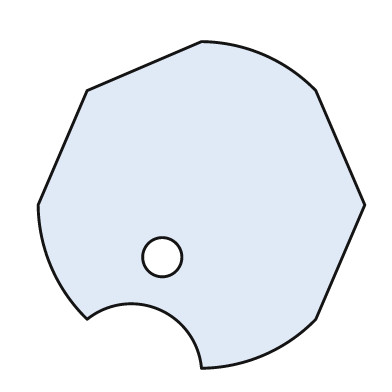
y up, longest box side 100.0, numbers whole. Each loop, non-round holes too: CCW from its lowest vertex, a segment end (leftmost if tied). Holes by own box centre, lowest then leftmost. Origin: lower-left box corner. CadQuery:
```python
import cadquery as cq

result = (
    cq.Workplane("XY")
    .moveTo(50.0, 0.0)
    .threePointArc((69.0, 4.0), (85.0, 15.0))
    .lineTo(100.0, 50.0)
    .lineTo(85.0, 85.0)
    .threePointArc((69.0, 96.0), (50.0, 100.0))
    .lineTo(15.0, 85.0)
    .lineTo(0.0, 50.0)
    .threePointArc((4.0, 31.0), (15.0, 15.0))
    .threePointArc((37.0, 18.0), (50.0, 0.0))
    .close()
    .moveTo(38.0, 34.0)
    .circle(6.0)
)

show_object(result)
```